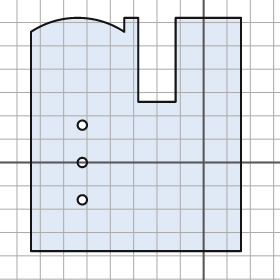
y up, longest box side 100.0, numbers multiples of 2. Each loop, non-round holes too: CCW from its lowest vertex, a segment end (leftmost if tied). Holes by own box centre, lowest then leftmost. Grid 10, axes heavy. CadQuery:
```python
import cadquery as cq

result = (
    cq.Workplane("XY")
    .moveTo(-74.0, -38.0)
    .lineTo(16.0, -38.0)
    .lineTo(16.0, 62.0)
    .lineTo(-12.0, 62.0)
    .lineTo(-12.0, 26.0)
    .lineTo(-28.0, 26.0)
    .lineTo(-28.0, 62.0)
    .lineTo(-34.0, 62.0)
    .lineTo(-34.0, 56.0)
    .threePointArc((-54.0, 62.0), (-74.0, 56.0))
    .close()
    .moveTo(-52.0, -16.0)
    .circle(2.0)
    .moveTo(-52.0, 0.0)
    .circle(2.0)
    .moveTo(-52.0, 16.0)
    .circle(2.0)
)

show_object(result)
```